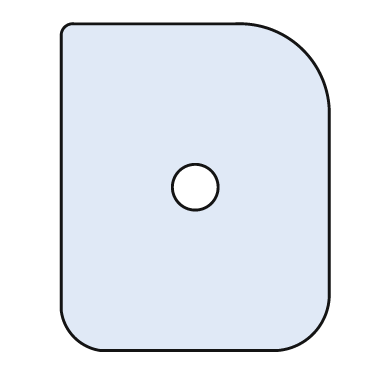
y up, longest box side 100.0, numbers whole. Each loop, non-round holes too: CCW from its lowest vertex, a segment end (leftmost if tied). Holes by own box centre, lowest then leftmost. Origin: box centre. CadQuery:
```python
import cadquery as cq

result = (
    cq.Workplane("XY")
    .moveTo(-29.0, -50.0)
    .lineTo(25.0, -50.0)
    .threePointArc((36.0, -45.0), (41.0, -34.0))
    .lineTo(41.0, 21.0)
    .threePointArc((33.0, 42.0), (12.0, 50.0))
    .lineTo(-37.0, 50.0)
    .threePointArc((-40.0, 49.0), (-41.0, 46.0))
    .lineTo(-41.0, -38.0)
    .threePointArc((-37.0, -46.0), (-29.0, -50.0))
    .close()
    .moveTo(0.0, 0.0)
    .circle(7.0)
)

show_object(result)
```